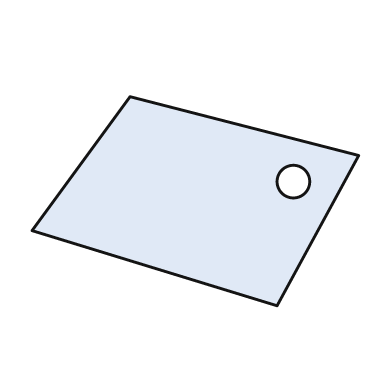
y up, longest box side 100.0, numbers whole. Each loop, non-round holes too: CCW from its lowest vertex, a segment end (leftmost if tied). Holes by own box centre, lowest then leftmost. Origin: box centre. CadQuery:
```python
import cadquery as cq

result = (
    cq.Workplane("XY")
    .moveTo(25.0, -32.0)
    .lineTo(50.0, 14.0)
    .lineTo(-20.0, 32.0)
    .lineTo(-50.0, -9.0)
    .close()
    .moveTo(30.0, 6.0)
    .circle(5.0)
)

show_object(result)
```